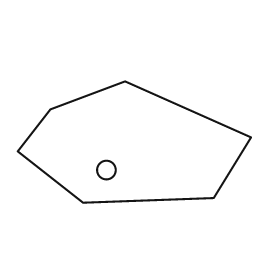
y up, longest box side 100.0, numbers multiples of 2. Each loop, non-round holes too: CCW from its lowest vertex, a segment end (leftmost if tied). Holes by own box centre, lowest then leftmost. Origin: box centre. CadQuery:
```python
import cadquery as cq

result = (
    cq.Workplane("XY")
    .moveTo(-22.0, -26.0)
    .lineTo(34.0, -24.0)
    .lineTo(50.0, 2.0)
    .lineTo(-4.0, 26.0)
    .lineTo(-36.0, 14.0)
    .lineTo(-50.0, -4.0)
    .close()
    .moveTo(-12.0, -12.0)
    .circle(4.0)
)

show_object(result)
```